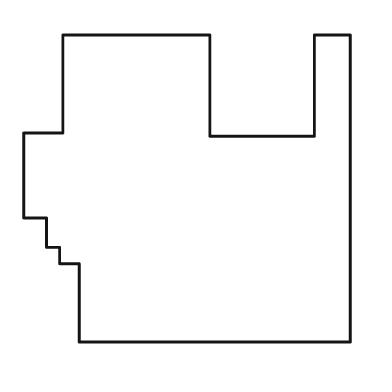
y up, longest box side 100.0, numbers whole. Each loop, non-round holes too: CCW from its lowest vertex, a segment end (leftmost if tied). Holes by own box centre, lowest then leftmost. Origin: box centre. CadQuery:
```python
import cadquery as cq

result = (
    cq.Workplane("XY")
    .moveTo(-33.0, -47.0)
    .lineTo(50.0, -47.0)
    .lineTo(50.0, 47.0)
    .lineTo(39.0, 47.0)
    .lineTo(39.0, 16.0)
    .lineTo(7.0, 16.0)
    .lineTo(7.0, 47.0)
    .lineTo(-38.0, 47.0)
    .lineTo(-38.0, 17.0)
    .lineTo(-50.0, 17.0)
    .lineTo(-50.0, -9.0)
    .lineTo(-43.0, -9.0)
    .lineTo(-43.0, -18.0)
    .lineTo(-39.0, -18.0)
    .lineTo(-39.0, -23.0)
    .lineTo(-33.0, -23.0)
    .close()
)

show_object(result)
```